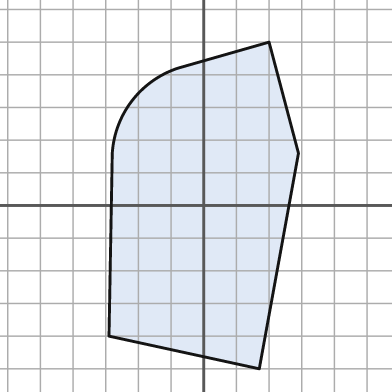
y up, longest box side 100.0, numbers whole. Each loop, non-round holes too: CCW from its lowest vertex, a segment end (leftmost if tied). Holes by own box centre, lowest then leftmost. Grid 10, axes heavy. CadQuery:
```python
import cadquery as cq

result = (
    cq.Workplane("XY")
    .moveTo(17.0, -50.0)
    .lineTo(29.0, 16.0)
    .lineTo(20.0, 50.0)
    .lineTo(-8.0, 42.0)
    .threePointArc((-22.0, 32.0), (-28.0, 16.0))
    .lineTo(-29.0, -40.0)
    .close()
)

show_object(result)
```